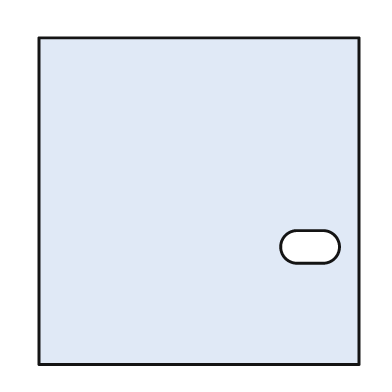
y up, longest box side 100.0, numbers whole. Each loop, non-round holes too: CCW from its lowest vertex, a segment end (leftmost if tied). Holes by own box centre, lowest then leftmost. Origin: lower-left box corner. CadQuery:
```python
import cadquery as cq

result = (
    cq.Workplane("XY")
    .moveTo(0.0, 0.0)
    .lineTo(98.0, 0.0)
    .lineTo(98.0, 100.0)
    .lineTo(0.0, 100.0)
    .close()
    .moveTo(79.0, 31.0)
    .lineTo(87.0, 31.0)
    .threePointArc((92.0, 36.0), (87.0, 41.0))
    .lineTo(79.0, 41.0)
    .threePointArc((74.0, 36.0), (79.0, 31.0))
    .close()
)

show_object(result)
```